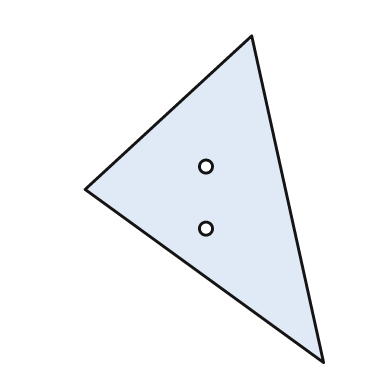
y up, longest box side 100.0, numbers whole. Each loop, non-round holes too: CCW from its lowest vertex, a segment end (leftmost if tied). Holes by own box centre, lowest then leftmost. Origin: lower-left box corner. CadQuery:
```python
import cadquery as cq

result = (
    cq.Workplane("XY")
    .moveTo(73.0, 0.0)
    .lineTo(51.0, 100.0)
    .lineTo(0.0, 53.0)
    .close()
    .moveTo(37.0, 41.0)
    .circle(2.0)
    .moveTo(37.0, 60.0)
    .circle(2.0)
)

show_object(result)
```